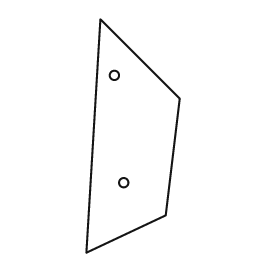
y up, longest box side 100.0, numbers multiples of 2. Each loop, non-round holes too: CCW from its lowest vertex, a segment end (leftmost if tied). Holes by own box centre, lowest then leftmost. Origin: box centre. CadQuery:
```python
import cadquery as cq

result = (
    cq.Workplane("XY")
    .moveTo(-20.0, -50.0)
    .lineTo(14.0, -34.0)
    .lineTo(20.0, 16.0)
    .lineTo(-14.0, 50.0)
    .close()
    .moveTo(-4.0, -20.0)
    .circle(2.0)
    .moveTo(-8.0, 26.0)
    .circle(2.0)
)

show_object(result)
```